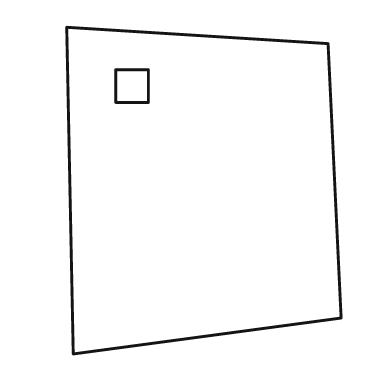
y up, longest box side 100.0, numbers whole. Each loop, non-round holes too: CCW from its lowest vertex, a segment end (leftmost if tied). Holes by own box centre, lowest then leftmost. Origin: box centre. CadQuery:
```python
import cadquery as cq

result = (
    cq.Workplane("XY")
    .moveTo(-40.0, -50.0)
    .lineTo(42.0, -39.0)
    .lineTo(38.0, 45.0)
    .lineTo(-42.0, 50.0)
    .close()
    .moveTo(-27.0, 27.0)
    .lineTo(-17.0, 27.0)
    .lineTo(-17.0, 37.0)
    .lineTo(-27.0, 37.0)
    .close()
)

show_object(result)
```